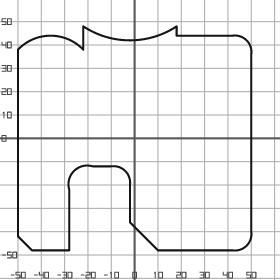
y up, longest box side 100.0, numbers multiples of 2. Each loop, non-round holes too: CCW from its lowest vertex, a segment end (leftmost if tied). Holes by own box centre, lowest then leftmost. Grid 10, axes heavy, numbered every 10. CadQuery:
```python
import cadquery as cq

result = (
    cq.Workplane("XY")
    .moveTo(-44.0, -48.0)
    .lineTo(-28.0, -48.0)
    .lineTo(-28.0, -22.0)
    .threePointArc((-26.0, -14.0), (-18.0, -12.0))
    .lineTo(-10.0, -12.0)
    .threePointArc((-4.0, -14.0), (-2.0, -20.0))
    .lineTo(-2.0, -36.0)
    .lineTo(10.0, -48.0)
    .lineTo(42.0, -48.0)
    .threePointArc((48.0, -46.0), (50.0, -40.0))
    .lineTo(50.0, 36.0)
    .threePointArc((48.0, 42.0), (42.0, 44.0))
    .lineTo(18.0, 44.0)
    .lineTo(18.0, 48.0)
    .threePointArc((-2.0, 42.0), (-22.0, 48.0))
    .lineTo(-22.0, 38.0)
    .threePointArc((-36.0, 44.0), (-50.0, 38.0))
    .lineTo(-50.0, -42.0)
    .close()
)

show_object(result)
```